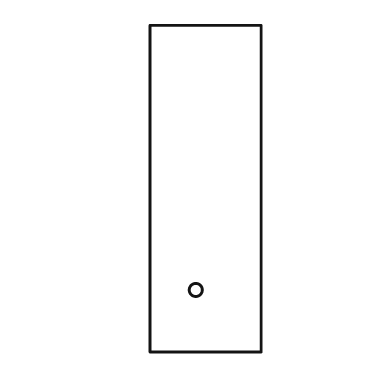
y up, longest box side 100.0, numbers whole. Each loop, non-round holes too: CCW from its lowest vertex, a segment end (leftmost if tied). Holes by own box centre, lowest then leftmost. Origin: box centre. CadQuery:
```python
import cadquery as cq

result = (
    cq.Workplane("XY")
    .moveTo(-17.0, -50.0)
    .lineTo(17.0, -50.0)
    .lineTo(17.0, 50.0)
    .lineTo(-17.0, 50.0)
    .close()
    .moveTo(-3.0, -31.0)
    .circle(2.0)
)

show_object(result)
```